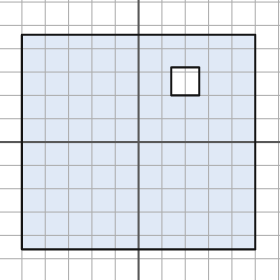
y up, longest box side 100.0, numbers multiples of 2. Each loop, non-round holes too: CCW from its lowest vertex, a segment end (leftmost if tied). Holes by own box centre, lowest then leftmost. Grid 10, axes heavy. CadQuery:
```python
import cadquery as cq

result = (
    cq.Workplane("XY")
    .moveTo(-50.0, -46.0)
    .lineTo(50.0, -46.0)
    .lineTo(50.0, 46.0)
    .lineTo(-50.0, 46.0)
    .close()
    .moveTo(14.0, 20.0)
    .lineTo(26.0, 20.0)
    .lineTo(26.0, 32.0)
    .lineTo(14.0, 32.0)
    .close()
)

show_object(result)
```